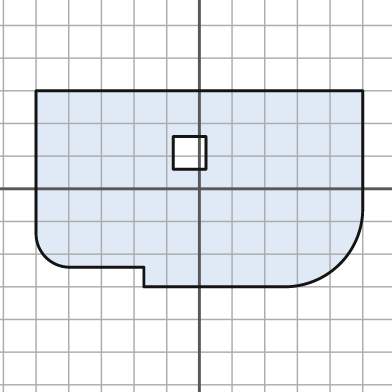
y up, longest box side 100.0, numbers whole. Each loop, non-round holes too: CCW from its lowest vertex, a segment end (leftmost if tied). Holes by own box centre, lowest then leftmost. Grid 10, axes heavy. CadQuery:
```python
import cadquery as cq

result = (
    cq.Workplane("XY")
    .moveTo(-17.0, -30.0)
    .lineTo(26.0, -30.0)
    .threePointArc((43.0, -23.0), (50.0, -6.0))
    .lineTo(50.0, 30.0)
    .lineTo(-50.0, 30.0)
    .lineTo(-50.0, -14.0)
    .threePointArc((-47.0, -21.0), (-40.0, -24.0))
    .lineTo(-17.0, -24.0)
    .close()
    .moveTo(-8.0, 6.0)
    .lineTo(2.0, 6.0)
    .lineTo(2.0, 16.0)
    .lineTo(-8.0, 16.0)
    .close()
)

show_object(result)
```